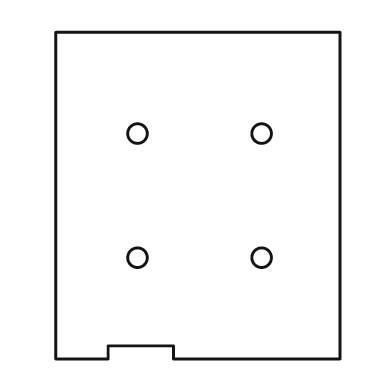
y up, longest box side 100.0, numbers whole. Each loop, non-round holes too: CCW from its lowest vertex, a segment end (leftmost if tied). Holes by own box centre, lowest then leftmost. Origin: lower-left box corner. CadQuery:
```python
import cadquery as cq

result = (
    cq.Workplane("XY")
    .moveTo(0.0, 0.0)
    .lineTo(16.0, 0.0)
    .lineTo(16.0, 4.0)
    .lineTo(36.0, 4.0)
    .lineTo(36.0, 0.0)
    .lineTo(87.0, 0.0)
    .lineTo(87.0, 100.0)
    .lineTo(0.0, 100.0)
    .close()
    .moveTo(25.0, 31.0)
    .circle(3.0)
    .moveTo(63.0, 31.0)
    .circle(3.0)
    .moveTo(25.0, 69.0)
    .circle(3.0)
    .moveTo(63.0, 69.0)
    .circle(3.0)
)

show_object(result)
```